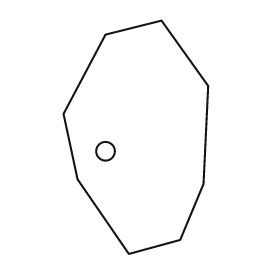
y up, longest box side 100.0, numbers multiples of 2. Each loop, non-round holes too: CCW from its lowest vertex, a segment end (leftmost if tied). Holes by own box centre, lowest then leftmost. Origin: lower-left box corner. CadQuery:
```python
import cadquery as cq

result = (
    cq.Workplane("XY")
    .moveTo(28.0, 0.0)
    .lineTo(50.0, 6.0)
    .lineTo(60.0, 30.0)
    .lineTo(62.0, 72.0)
    .lineTo(42.0, 100.0)
    .lineTo(18.0, 94.0)
    .lineTo(0.0, 60.0)
    .lineTo(6.0, 32.0)
    .close()
    .moveTo(18.0, 44.0)
    .circle(4.0)
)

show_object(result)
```